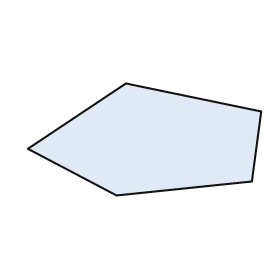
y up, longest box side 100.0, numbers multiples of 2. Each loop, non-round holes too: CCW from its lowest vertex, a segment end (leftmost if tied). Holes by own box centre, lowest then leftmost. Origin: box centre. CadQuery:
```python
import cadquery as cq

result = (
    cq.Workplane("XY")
    .moveTo(-12.0, -24.0)
    .lineTo(46.0, -18.0)
    .lineTo(50.0, 12.0)
    .lineTo(-8.0, 24.0)
    .lineTo(-50.0, -4.0)
    .close()
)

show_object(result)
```